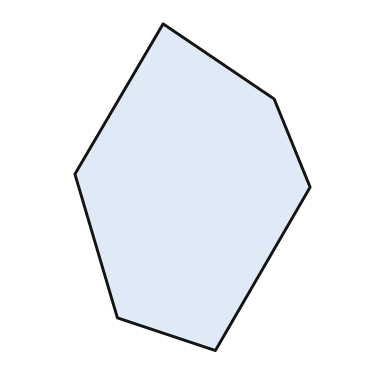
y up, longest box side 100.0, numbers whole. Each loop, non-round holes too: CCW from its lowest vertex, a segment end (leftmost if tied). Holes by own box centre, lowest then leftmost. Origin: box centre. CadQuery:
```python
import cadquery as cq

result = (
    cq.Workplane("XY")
    .moveTo(7.0, -50.0)
    .lineTo(36.0, 0.0)
    .lineTo(25.0, 27.0)
    .lineTo(-9.0, 50.0)
    .lineTo(-36.0, 4.0)
    .lineTo(-23.0, -40.0)
    .close()
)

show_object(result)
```